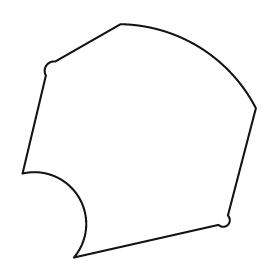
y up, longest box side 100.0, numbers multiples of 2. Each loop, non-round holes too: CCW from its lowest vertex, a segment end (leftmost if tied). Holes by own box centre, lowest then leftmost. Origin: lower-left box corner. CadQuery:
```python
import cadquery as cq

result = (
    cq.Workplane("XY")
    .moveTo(22.0, 0.0)
    .lineTo(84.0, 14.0)
    .threePointArc((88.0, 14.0), (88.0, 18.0))
    .lineTo(100.0, 64.0)
    .threePointArc((76.0, 90.0), (42.0, 100.0))
    .lineTo(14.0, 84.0)
    .threePointArc((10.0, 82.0), (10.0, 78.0))
    .lineTo(0.0, 36.0)
    .threePointArc((24.0, 26.0), (22.0, 0.0))
    .close()
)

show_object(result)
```